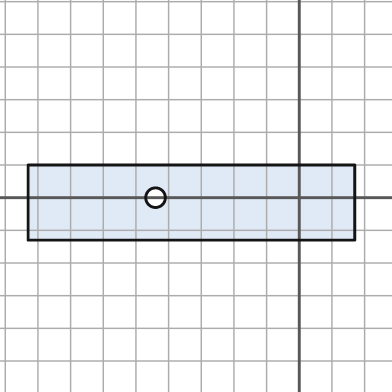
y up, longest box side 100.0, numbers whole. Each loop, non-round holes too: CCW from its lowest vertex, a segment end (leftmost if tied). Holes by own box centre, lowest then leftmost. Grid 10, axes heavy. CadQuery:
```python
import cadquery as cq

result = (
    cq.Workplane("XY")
    .moveTo(-83.0, -13.0)
    .lineTo(17.0, -13.0)
    .lineTo(17.0, 10.0)
    .lineTo(-83.0, 10.0)
    .close()
    .moveTo(-44.0, 0.0)
    .circle(3.0)
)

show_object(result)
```